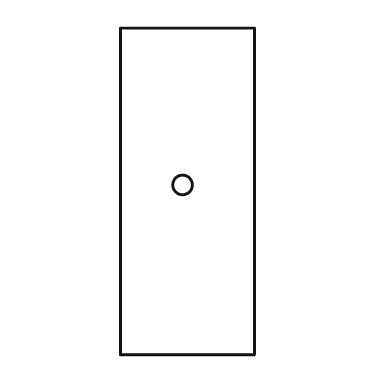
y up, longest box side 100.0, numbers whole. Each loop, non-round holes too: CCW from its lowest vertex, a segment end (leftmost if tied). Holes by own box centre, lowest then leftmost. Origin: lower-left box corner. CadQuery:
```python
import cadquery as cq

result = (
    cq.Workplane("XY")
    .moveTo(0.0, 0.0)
    .lineTo(41.0, 0.0)
    .lineTo(41.0, 100.0)
    .lineTo(0.0, 100.0)
    .close()
    .moveTo(19.0, 52.0)
    .circle(3.0)
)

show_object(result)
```